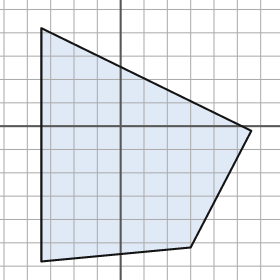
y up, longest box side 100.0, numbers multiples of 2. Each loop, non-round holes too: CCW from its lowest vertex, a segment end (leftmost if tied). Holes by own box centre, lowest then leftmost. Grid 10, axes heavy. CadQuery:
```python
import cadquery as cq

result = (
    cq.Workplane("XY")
    .moveTo(-34.0, -58.0)
    .lineTo(30.0, -52.0)
    .lineTo(56.0, -2.0)
    .lineTo(-34.0, 42.0)
    .close()
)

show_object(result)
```